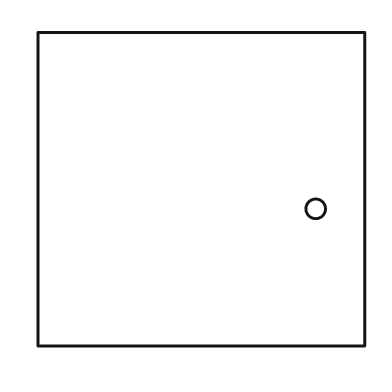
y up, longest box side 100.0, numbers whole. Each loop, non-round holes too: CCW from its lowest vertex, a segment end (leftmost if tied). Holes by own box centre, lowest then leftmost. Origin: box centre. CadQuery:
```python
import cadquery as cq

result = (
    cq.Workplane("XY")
    .moveTo(-50.0, -48.0)
    .lineTo(50.0, -48.0)
    .lineTo(50.0, 48.0)
    .lineTo(-50.0, 48.0)
    .close()
    .moveTo(35.0, -6.0)
    .circle(3.0)
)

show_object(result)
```